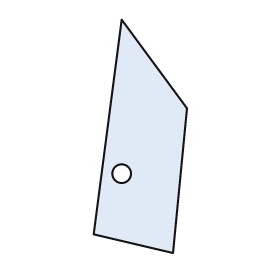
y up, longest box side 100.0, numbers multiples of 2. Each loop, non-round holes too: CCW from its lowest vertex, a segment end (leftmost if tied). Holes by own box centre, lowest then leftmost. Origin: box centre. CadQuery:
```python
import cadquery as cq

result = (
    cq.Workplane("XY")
    .moveTo(14.0, -50.0)
    .lineTo(20.0, 12.0)
    .lineTo(-8.0, 50.0)
    .lineTo(-20.0, -42.0)
    .close()
    .moveTo(-8.0, -16.0)
    .circle(4.0)
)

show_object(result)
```